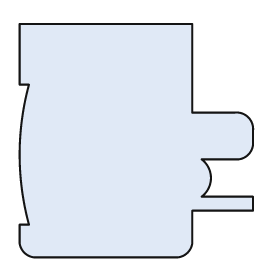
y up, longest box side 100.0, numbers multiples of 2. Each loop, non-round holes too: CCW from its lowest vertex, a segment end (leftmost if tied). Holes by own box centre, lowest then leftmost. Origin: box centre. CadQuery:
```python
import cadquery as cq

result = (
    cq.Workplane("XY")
    .moveTo(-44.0, -50.0)
    .lineTo(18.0, -50.0)
    .threePointArc((22.0, -48.0), (24.0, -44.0))
    .lineTo(24.0, -30.0)
    .lineTo(50.0, -30.0)
    .lineTo(50.0, -24.0)
    .lineTo(28.0, -24.0)
    .threePointArc((32.0, -16.0), (28.0, -8.0))
    .lineTo(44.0, -8.0)
    .threePointArc((48.0, -6.0), (50.0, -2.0))
    .lineTo(50.0, 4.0)
    .threePointArc((48.0, 10.0), (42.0, 12.0))
    .lineTo(24.0, 12.0)
    .lineTo(24.0, 50.0)
    .lineTo(-50.0, 50.0)
    .lineTo(-50.0, 24.0)
    .lineTo(-46.0, 24.0)
    .threePointArc((-50.0, -6.0), (-46.0, -36.0))
    .lineTo(-50.0, -36.0)
    .lineTo(-50.0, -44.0)
    .threePointArc((-48.0, -48.0), (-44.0, -50.0))
    .close()
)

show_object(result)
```